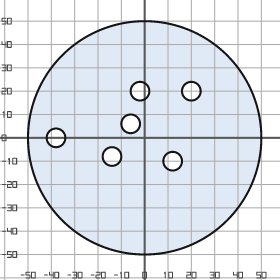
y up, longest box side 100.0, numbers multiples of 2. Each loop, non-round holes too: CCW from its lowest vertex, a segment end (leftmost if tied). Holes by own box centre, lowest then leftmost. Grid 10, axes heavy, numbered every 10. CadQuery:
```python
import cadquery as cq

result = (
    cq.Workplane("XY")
    .moveTo(0.0, 0.0)
    .circle(50.0)
    .moveTo(12.0, -10.0)
    .circle(4.0)
    .moveTo(-14.0, -8.0)
    .circle(4.0)
    .moveTo(-38.0, 0.0)
    .circle(4.0)
    .moveTo(-6.0, 6.0)
    .circle(4.0)
    .moveTo(-2.0, 20.0)
    .circle(4.0)
    .moveTo(20.0, 20.0)
    .circle(4.0)
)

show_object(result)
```